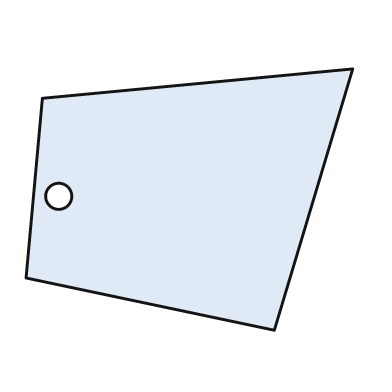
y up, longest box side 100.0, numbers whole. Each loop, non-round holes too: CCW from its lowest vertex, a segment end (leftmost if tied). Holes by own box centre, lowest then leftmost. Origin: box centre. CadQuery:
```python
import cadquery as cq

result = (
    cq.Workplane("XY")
    .moveTo(26.0, -40.0)
    .lineTo(50.0, 40.0)
    .lineTo(-45.0, 31.0)
    .lineTo(-50.0, -24.0)
    .close()
    .moveTo(-40.0, 1.0)
    .circle(4.0)
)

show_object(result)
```